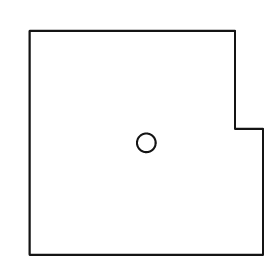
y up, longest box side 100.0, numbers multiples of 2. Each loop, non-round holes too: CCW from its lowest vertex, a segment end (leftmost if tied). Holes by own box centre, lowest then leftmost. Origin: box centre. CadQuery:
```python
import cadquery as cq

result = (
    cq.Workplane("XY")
    .moveTo(-50.0, -48.0)
    .lineTo(50.0, -48.0)
    .lineTo(50.0, 6.0)
    .lineTo(38.0, 6.0)
    .lineTo(38.0, 48.0)
    .lineTo(-50.0, 48.0)
    .close()
    .moveTo(0.0, 0.0)
    .circle(4.0)
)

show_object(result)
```